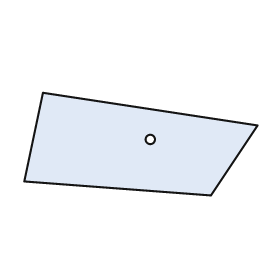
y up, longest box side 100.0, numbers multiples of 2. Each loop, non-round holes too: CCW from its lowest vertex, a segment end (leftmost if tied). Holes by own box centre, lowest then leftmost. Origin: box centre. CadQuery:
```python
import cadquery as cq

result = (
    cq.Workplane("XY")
    .moveTo(30.0, -22.0)
    .lineTo(50.0, 8.0)
    .lineTo(-42.0, 22.0)
    .lineTo(-50.0, -16.0)
    .close()
    .moveTo(4.0, 2.0)
    .circle(2.0)
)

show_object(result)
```